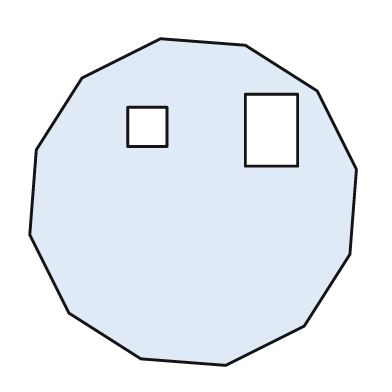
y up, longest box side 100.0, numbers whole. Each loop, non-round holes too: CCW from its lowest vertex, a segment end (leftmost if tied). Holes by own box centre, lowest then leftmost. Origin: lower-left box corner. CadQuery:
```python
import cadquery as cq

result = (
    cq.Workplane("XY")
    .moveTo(60.0, 0.0)
    .lineTo(84.0, 12.0)
    .lineTo(98.0, 34.0)
    .lineTo(100.0, 60.0)
    .lineTo(88.0, 84.0)
    .lineTo(66.0, 98.0)
    .lineTo(40.0, 100.0)
    .lineTo(16.0, 88.0)
    .lineTo(2.0, 66.0)
    .lineTo(0.0, 40.0)
    .lineTo(12.0, 16.0)
    .lineTo(34.0, 2.0)
    .close()
    .moveTo(66.0, 61.0)
    .lineTo(82.0, 61.0)
    .lineTo(82.0, 83.0)
    .lineTo(66.0, 83.0)
    .close()
    .moveTo(30.0, 67.0)
    .lineTo(42.0, 67.0)
    .lineTo(42.0, 79.0)
    .lineTo(30.0, 79.0)
    .close()
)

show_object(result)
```